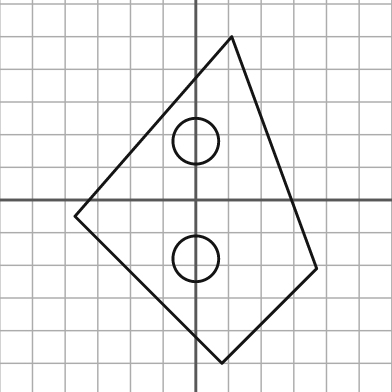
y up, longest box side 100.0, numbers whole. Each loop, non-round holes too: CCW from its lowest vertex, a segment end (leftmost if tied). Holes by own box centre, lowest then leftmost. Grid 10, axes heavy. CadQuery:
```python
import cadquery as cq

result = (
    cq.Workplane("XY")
    .moveTo(8.0, -50.0)
    .lineTo(37.0, -21.0)
    .lineTo(11.0, 50.0)
    .lineTo(-37.0, -5.0)
    .close()
    .moveTo(0.0, -18.0)
    .circle(7.0)
    .moveTo(0.0, 18.0)
    .circle(7.0)
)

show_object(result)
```